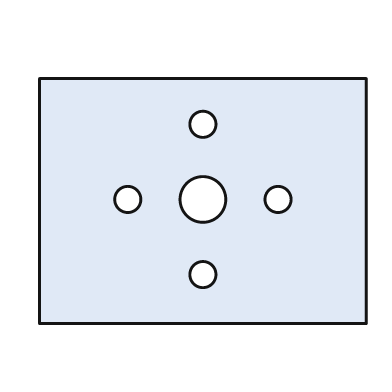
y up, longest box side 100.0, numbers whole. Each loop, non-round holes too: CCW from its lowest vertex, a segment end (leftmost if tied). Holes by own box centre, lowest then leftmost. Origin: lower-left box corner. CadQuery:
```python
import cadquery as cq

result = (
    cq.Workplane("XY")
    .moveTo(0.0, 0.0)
    .lineTo(100.0, 0.0)
    .lineTo(100.0, 75.0)
    .lineTo(0.0, 75.0)
    .close()
    .moveTo(50.0, 15.0)
    .circle(4.0)
    .moveTo(27.0, 38.0)
    .circle(4.0)
    .moveTo(50.0, 38.0)
    .circle(7.0)
    .moveTo(73.0, 38.0)
    .circle(4.0)
    .moveTo(50.0, 61.0)
    .circle(4.0)
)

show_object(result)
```